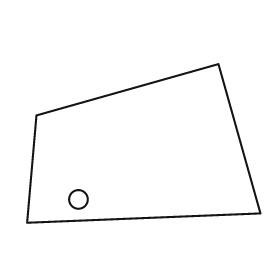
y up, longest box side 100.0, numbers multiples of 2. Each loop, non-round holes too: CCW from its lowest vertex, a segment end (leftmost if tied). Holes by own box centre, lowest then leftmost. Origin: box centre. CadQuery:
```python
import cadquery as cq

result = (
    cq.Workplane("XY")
    .moveTo(-50.0, -34.0)
    .lineTo(50.0, -30.0)
    .lineTo(32.0, 34.0)
    .lineTo(-46.0, 12.0)
    .close()
    .moveTo(-28.0, -24.0)
    .circle(4.0)
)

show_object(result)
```